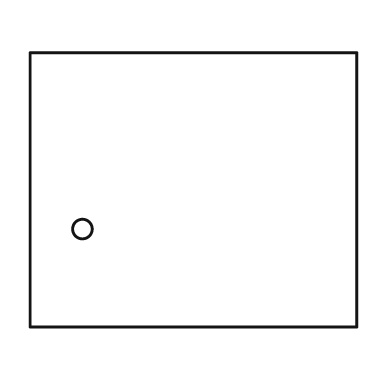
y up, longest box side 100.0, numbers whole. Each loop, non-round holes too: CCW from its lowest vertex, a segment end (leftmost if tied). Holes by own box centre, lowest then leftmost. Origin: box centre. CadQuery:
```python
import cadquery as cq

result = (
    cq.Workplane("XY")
    .moveTo(-50.0, -42.0)
    .lineTo(50.0, -42.0)
    .lineTo(50.0, 42.0)
    .lineTo(-50.0, 42.0)
    .close()
    .moveTo(-34.0, -12.0)
    .circle(3.0)
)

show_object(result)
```